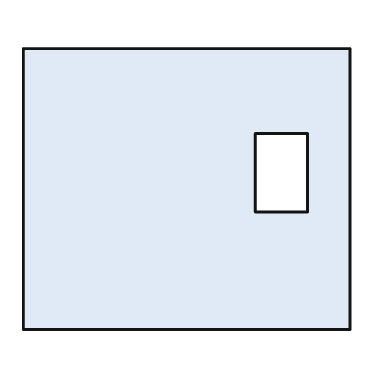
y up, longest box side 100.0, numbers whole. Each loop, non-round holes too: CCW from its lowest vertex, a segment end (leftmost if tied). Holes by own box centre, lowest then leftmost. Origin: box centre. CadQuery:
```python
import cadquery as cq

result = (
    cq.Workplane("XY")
    .moveTo(-50.0, -43.0)
    .lineTo(50.0, -43.0)
    .lineTo(50.0, 43.0)
    .lineTo(-50.0, 43.0)
    .close()
    .moveTo(21.0, -7.0)
    .lineTo(37.0, -7.0)
    .lineTo(37.0, 17.0)
    .lineTo(21.0, 17.0)
    .close()
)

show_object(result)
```